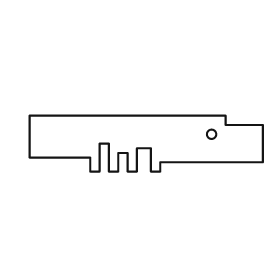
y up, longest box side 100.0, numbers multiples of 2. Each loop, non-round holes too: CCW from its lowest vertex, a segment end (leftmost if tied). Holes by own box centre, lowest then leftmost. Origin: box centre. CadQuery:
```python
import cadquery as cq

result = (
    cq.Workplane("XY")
    .moveTo(-24.0, -12.0)
    .lineTo(-20.0, -12.0)
    .lineTo(-20.0, 0.0)
    .lineTo(-16.0, 0.0)
    .lineTo(-16.0, -12.0)
    .lineTo(-12.0, -12.0)
    .lineTo(-12.0, -4.0)
    .lineTo(-8.0, -4.0)
    .lineTo(-8.0, -12.0)
    .lineTo(-4.0, -12.0)
    .lineTo(-4.0, -2.0)
    .lineTo(2.0, -2.0)
    .lineTo(2.0, -12.0)
    .lineTo(6.0, -12.0)
    .lineTo(6.0, -8.0)
    .lineTo(50.0, -8.0)
    .lineTo(50.0, 8.0)
    .lineTo(34.0, 8.0)
    .lineTo(34.0, 12.0)
    .lineTo(-50.0, 12.0)
    .lineTo(-50.0, -6.0)
    .lineTo(-24.0, -6.0)
    .close()
    .moveTo(28.0, 4.0)
    .circle(2.0)
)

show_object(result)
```